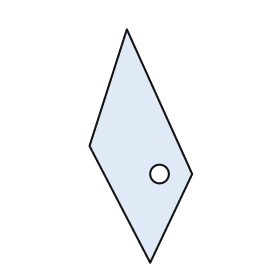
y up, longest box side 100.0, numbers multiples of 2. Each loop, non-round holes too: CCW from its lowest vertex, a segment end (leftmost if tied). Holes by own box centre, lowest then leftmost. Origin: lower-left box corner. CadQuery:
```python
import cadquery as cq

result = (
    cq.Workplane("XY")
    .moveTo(26.0, 0.0)
    .lineTo(44.0, 38.0)
    .lineTo(16.0, 100.0)
    .lineTo(0.0, 50.0)
    .close()
    .moveTo(30.0, 38.0)
    .circle(4.0)
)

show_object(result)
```